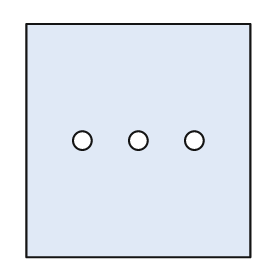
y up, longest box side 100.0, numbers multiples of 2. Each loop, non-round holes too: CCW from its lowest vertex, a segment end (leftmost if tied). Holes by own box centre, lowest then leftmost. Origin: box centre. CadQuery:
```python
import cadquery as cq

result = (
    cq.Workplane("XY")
    .moveTo(-48.0, -50.0)
    .lineTo(48.0, -50.0)
    .lineTo(48.0, 50.0)
    .lineTo(-48.0, 50.0)
    .close()
    .moveTo(-24.0, 0.0)
    .circle(4.0)
    .moveTo(0.0, 0.0)
    .circle(4.0)
    .moveTo(24.0, 0.0)
    .circle(4.0)
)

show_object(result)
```